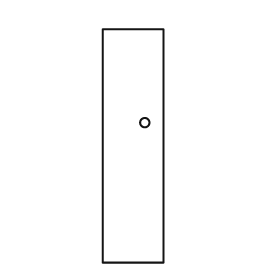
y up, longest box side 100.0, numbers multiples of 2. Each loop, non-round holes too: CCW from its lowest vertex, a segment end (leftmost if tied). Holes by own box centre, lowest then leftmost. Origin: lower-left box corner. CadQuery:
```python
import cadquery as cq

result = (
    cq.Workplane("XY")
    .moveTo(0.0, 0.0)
    .lineTo(26.0, 0.0)
    .lineTo(26.0, 100.0)
    .lineTo(0.0, 100.0)
    .close()
    .moveTo(18.0, 60.0)
    .circle(2.0)
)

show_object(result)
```